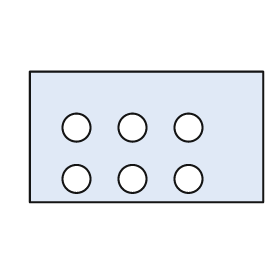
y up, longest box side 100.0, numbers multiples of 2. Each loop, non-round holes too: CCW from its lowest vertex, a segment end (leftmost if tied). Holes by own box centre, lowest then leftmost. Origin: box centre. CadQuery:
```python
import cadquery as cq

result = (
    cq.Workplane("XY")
    .moveTo(-50.0, -28.0)
    .lineTo(50.0, -28.0)
    .lineTo(50.0, 28.0)
    .lineTo(-50.0, 28.0)
    .close()
    .moveTo(-30.0, -18.0)
    .circle(6.0)
    .moveTo(-6.0, -18.0)
    .circle(6.0)
    .moveTo(18.0, -18.0)
    .circle(6.0)
    .moveTo(-30.0, 4.0)
    .circle(6.0)
    .moveTo(-6.0, 4.0)
    .circle(6.0)
    .moveTo(18.0, 4.0)
    .circle(6.0)
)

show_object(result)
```